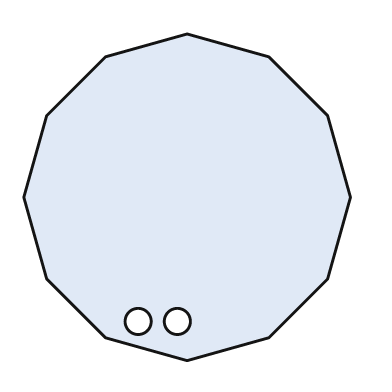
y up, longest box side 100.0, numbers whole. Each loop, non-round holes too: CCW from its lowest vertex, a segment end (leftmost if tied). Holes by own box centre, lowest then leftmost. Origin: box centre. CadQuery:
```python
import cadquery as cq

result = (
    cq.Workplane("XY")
    .moveTo(0.0, -50.0)
    .lineTo(25.0, -43.0)
    .lineTo(43.0, -25.0)
    .lineTo(50.0, 0.0)
    .lineTo(43.0, 25.0)
    .lineTo(25.0, 43.0)
    .lineTo(0.0, 50.0)
    .lineTo(-25.0, 43.0)
    .lineTo(-43.0, 25.0)
    .lineTo(-50.0, 0.0)
    .lineTo(-43.0, -25.0)
    .lineTo(-25.0, -43.0)
    .close()
    .moveTo(-15.0, -38.0)
    .circle(4.0)
    .moveTo(-3.0, -38.0)
    .circle(4.0)
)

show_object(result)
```